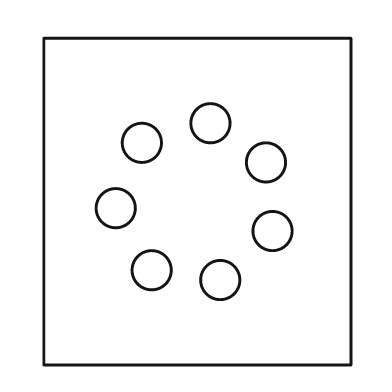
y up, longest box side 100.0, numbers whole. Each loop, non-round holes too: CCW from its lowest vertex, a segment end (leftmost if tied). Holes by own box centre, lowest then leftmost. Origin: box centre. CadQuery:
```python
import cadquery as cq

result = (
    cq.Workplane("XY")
    .moveTo(-47.0, -50.0)
    .lineTo(47.0, -50.0)
    .lineTo(47.0, 50.0)
    .lineTo(-47.0, 50.0)
    .close()
    .moveTo(7.0, -24.0)
    .circle(6.0)
    .moveTo(-14.0, -21.0)
    .circle(6.0)
    .moveTo(23.0, -9.0)
    .circle(6.0)
    .moveTo(-25.0, -2.0)
    .circle(6.0)
    .moveTo(21.0, 12.0)
    .circle(6.0)
    .moveTo(-17.0, 18.0)
    .circle(6.0)
    .moveTo(4.0, 24.0)
    .circle(6.0)
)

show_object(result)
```